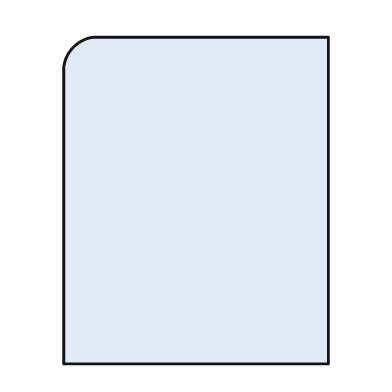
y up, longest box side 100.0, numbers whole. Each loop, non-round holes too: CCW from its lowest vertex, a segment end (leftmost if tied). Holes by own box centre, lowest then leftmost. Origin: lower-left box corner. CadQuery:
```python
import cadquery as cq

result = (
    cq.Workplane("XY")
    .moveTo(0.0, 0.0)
    .lineTo(81.0, 0.0)
    .lineTo(81.0, 100.0)
    .lineTo(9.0, 100.0)
    .threePointArc((3.0, 97.0), (0.0, 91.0))
    .close()
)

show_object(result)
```